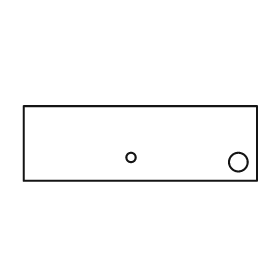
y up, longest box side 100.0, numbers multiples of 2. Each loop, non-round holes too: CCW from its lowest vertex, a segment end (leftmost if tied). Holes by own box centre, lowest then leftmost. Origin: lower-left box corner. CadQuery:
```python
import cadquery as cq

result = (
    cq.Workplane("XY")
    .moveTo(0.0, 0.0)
    .lineTo(100.0, 0.0)
    .lineTo(100.0, 32.0)
    .lineTo(0.0, 32.0)
    .close()
    .moveTo(92.0, 8.0)
    .circle(4.0)
    .moveTo(46.0, 10.0)
    .circle(2.0)
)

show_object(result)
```